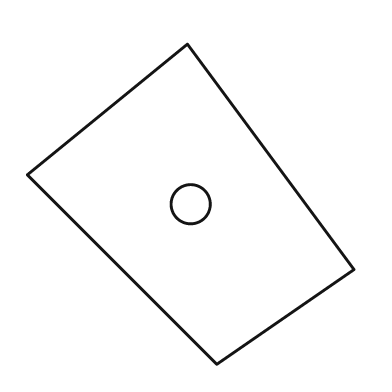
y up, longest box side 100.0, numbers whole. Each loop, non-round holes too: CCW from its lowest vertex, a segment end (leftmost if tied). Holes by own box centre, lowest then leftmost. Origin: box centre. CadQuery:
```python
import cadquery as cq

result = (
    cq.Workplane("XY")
    .moveTo(8.0, -49.0)
    .lineTo(50.0, -20.0)
    .lineTo(-1.0, 49.0)
    .lineTo(-50.0, 9.0)
    .close()
    .moveTo(0.0, 0.0)
    .circle(6.0)
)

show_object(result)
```